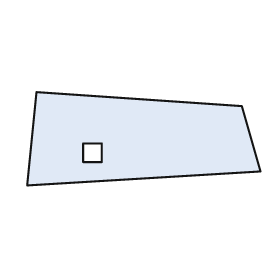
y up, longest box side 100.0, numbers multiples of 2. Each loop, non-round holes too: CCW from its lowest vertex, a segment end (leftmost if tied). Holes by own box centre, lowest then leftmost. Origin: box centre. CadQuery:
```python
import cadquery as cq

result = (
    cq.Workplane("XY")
    .moveTo(-50.0, -20.0)
    .lineTo(50.0, -14.0)
    .lineTo(42.0, 14.0)
    .lineTo(-46.0, 20.0)
    .close()
    .moveTo(-26.0, -10.0)
    .lineTo(-18.0, -10.0)
    .lineTo(-18.0, -2.0)
    .lineTo(-26.0, -2.0)
    .close()
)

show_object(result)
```